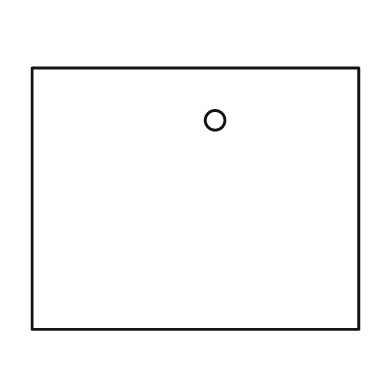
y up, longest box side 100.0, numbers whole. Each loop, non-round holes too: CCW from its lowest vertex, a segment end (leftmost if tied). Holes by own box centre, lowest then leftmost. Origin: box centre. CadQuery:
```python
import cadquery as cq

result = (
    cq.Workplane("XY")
    .moveTo(-50.0, -40.0)
    .lineTo(50.0, -40.0)
    .lineTo(50.0, 40.0)
    .lineTo(-50.0, 40.0)
    .close()
    .moveTo(6.0, 24.0)
    .circle(3.0)
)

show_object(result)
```